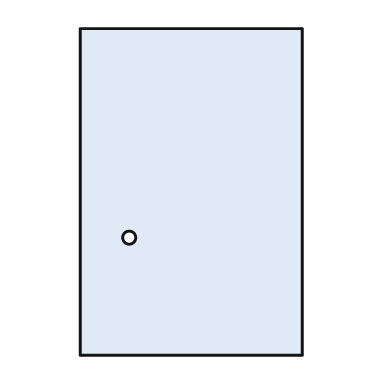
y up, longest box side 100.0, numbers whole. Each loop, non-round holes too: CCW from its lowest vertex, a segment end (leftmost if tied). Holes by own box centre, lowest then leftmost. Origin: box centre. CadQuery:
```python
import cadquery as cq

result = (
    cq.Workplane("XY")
    .moveTo(-34.0, -50.0)
    .lineTo(34.0, -50.0)
    .lineTo(34.0, 50.0)
    .lineTo(-34.0, 50.0)
    .close()
    .moveTo(-19.0, -14.0)
    .circle(2.0)
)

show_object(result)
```